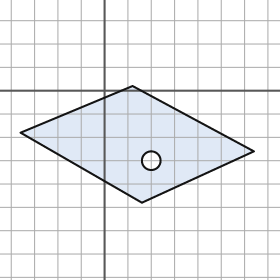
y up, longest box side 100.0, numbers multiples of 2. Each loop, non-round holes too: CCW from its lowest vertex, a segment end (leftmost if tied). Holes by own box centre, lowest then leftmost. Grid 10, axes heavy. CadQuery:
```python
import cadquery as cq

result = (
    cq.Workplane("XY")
    .moveTo(16.0, -48.0)
    .lineTo(64.0, -26.0)
    .lineTo(12.0, 2.0)
    .lineTo(-36.0, -18.0)
    .close()
    .moveTo(20.0, -30.0)
    .circle(4.0)
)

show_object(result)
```